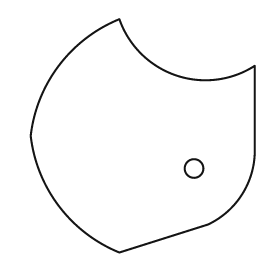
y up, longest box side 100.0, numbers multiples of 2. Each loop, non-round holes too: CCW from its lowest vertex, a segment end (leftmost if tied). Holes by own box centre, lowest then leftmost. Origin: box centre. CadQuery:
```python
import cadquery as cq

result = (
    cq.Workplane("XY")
    .moveTo(-10.0, -50.0)
    .lineTo(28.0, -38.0)
    .threePointArc((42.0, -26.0), (48.0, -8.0))
    .lineTo(48.0, 30.0)
    .threePointArc((14.0, 26.0), (-10.0, 50.0))
    .threePointArc((-36.0, 30.0), (-48.0, 0.0))
    .threePointArc((-36.0, -30.0), (-10.0, -50.0))
    .close()
    .moveTo(22.0, -14.0)
    .circle(4.0)
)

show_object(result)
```